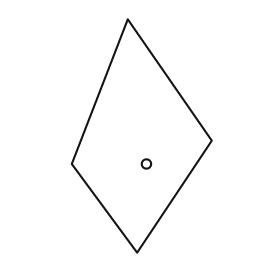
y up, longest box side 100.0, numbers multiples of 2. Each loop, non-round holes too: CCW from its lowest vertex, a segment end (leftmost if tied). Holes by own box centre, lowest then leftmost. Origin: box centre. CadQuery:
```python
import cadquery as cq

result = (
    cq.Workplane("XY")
    .moveTo(-2.0, -50.0)
    .lineTo(30.0, -2.0)
    .lineTo(-6.0, 50.0)
    .lineTo(-30.0, -12.0)
    .close()
    .moveTo(2.0, -12.0)
    .circle(2.0)
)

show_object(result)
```